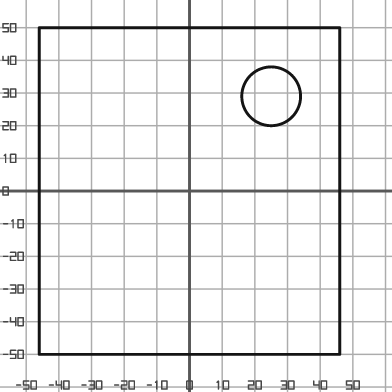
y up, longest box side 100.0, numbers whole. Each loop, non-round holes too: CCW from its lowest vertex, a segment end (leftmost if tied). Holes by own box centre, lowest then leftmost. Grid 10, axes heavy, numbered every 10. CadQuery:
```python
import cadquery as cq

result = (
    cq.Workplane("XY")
    .moveTo(-46.0, -50.0)
    .lineTo(46.0, -50.0)
    .lineTo(46.0, 50.0)
    .lineTo(-46.0, 50.0)
    .close()
    .moveTo(25.0, 29.0)
    .circle(9.0)
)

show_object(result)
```